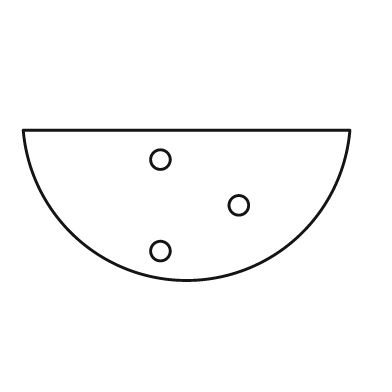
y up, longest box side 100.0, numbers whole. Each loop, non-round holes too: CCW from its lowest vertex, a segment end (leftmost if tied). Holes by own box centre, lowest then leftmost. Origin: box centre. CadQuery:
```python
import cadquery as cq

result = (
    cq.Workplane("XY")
    .moveTo(-50.0, 23.0)
    .threePointArc((0.0, -23.0), (50.0, 23.0))
    .close()
    .moveTo(-8.0, -14.0)
    .circle(3.0)
    .moveTo(16.0, 0.0)
    .circle(3.0)
    .moveTo(-8.0, 14.0)
    .circle(3.0)
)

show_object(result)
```